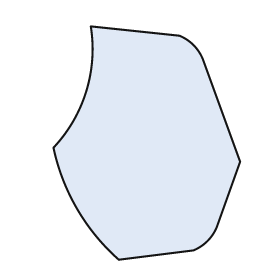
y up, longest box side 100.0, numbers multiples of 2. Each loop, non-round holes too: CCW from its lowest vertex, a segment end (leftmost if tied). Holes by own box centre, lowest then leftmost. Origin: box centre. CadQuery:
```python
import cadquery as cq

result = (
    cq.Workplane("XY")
    .moveTo(-12.0, -50.0)
    .lineTo(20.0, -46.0)
    .threePointArc((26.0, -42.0), (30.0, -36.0))
    .lineTo(40.0, -8.0)
    .lineTo(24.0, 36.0)
    .threePointArc((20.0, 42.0), (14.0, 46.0))
    .lineTo(-24.0, 50.0)
    .threePointArc((-26.0, 22.0), (-40.0, -2.0))
    .threePointArc((-30.0, -28.0), (-12.0, -50.0))
    .close()
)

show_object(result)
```